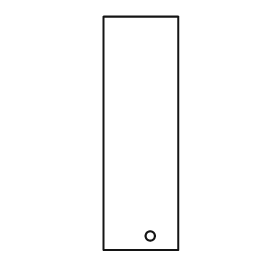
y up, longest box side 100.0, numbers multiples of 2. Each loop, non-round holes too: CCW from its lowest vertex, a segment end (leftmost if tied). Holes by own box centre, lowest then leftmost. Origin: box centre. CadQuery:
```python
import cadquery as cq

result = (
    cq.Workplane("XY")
    .moveTo(-16.0, -50.0)
    .lineTo(16.0, -50.0)
    .lineTo(16.0, 50.0)
    .lineTo(-16.0, 50.0)
    .close()
    .moveTo(4.0, -44.0)
    .circle(2.0)
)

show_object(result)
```